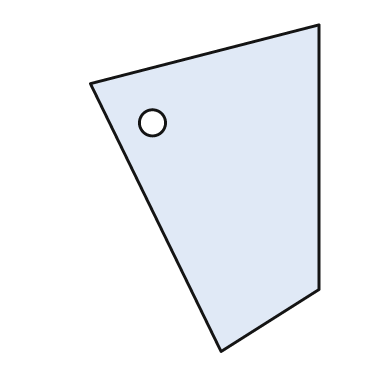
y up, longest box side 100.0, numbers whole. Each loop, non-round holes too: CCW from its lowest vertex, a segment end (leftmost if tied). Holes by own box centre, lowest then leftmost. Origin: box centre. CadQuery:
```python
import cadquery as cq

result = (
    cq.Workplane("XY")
    .moveTo(5.0, -50.0)
    .lineTo(35.0, -31.0)
    .lineTo(35.0, 50.0)
    .lineTo(-35.0, 32.0)
    .close()
    .moveTo(-16.0, 20.0)
    .circle(4.0)
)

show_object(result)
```